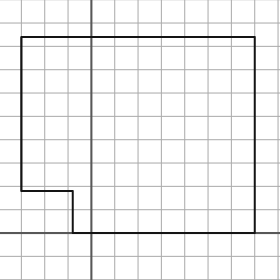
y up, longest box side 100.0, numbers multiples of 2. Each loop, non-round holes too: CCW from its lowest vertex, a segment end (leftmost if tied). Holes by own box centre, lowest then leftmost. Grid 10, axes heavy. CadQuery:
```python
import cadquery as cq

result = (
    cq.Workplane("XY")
    .moveTo(-8.0, 0.0)
    .lineTo(70.0, 0.0)
    .lineTo(70.0, 84.0)
    .lineTo(-30.0, 84.0)
    .lineTo(-30.0, 18.0)
    .lineTo(-8.0, 18.0)
    .close()
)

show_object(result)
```